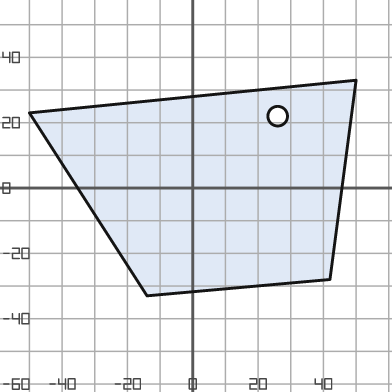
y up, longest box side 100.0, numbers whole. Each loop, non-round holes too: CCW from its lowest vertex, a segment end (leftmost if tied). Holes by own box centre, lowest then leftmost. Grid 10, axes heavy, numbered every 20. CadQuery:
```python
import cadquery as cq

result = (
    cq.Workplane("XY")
    .moveTo(-14.0, -33.0)
    .lineTo(42.0, -28.0)
    .lineTo(50.0, 33.0)
    .lineTo(-50.0, 23.0)
    .close()
    .moveTo(26.0, 22.0)
    .circle(3.0)
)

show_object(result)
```